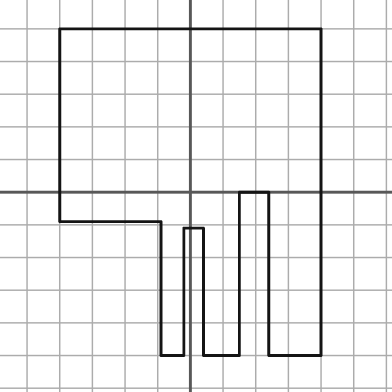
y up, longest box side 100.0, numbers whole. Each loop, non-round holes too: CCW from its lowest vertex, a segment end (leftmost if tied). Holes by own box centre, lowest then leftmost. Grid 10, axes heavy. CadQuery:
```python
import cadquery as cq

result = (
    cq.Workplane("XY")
    .moveTo(-9.0, -50.0)
    .lineTo(-2.0, -50.0)
    .lineTo(-2.0, -11.0)
    .lineTo(4.0, -11.0)
    .lineTo(4.0, -50.0)
    .lineTo(15.0, -50.0)
    .lineTo(15.0, 0.0)
    .lineTo(24.0, 0.0)
    .lineTo(24.0, -50.0)
    .lineTo(40.0, -50.0)
    .lineTo(40.0, 50.0)
    .lineTo(-40.0, 50.0)
    .lineTo(-40.0, -9.0)
    .lineTo(-9.0, -9.0)
    .close()
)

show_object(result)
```